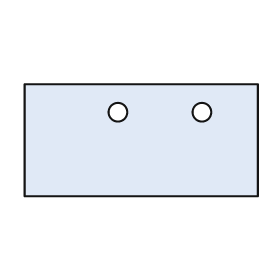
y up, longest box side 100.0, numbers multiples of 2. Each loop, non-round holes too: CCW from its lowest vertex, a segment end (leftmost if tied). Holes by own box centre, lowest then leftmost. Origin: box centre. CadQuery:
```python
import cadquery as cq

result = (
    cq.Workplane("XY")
    .moveTo(-50.0, -24.0)
    .lineTo(50.0, -24.0)
    .lineTo(50.0, 24.0)
    .lineTo(-50.0, 24.0)
    .close()
    .moveTo(-10.0, 12.0)
    .circle(4.0)
    .moveTo(26.0, 12.0)
    .circle(4.0)
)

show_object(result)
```